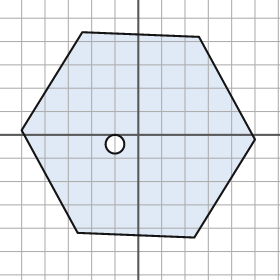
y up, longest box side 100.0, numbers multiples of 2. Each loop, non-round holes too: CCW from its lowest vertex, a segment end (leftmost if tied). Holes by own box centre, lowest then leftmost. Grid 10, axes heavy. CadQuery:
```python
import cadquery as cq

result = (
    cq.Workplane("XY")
    .moveTo(24.0, -44.0)
    .lineTo(50.0, -2.0)
    .lineTo(26.0, 42.0)
    .lineTo(-24.0, 44.0)
    .lineTo(-50.0, 2.0)
    .lineTo(-26.0, -42.0)
    .close()
    .moveTo(-10.0, -4.0)
    .circle(4.0)
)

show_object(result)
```